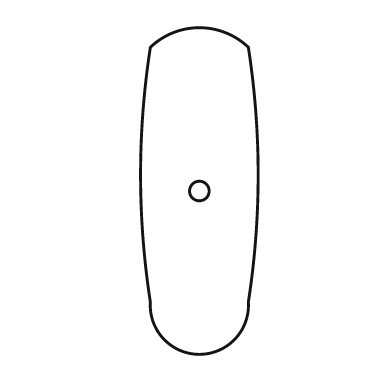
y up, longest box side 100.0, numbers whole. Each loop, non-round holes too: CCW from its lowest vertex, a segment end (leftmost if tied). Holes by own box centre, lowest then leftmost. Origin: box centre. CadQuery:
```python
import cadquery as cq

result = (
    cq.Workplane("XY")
    .moveTo(-15.0, -34.0)
    .threePointArc((0.0, -50.0), (15.0, -34.0))
    .threePointArc((18.0, 5.0), (15.0, 44.0))
    .threePointArc((0.0, 50.0), (-15.0, 44.0))
    .threePointArc((-18.0, 5.0), (-15.0, -34.0))
    .close()
    .moveTo(0.0, 0.0)
    .circle(3.0)
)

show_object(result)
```